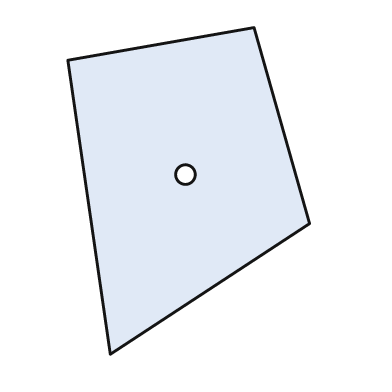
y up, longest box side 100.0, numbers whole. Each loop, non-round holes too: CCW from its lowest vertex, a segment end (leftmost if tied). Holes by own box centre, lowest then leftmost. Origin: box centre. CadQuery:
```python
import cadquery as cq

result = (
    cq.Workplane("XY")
    .moveTo(-24.0, -50.0)
    .lineTo(37.0, -10.0)
    .lineTo(20.0, 50.0)
    .lineTo(-37.0, 40.0)
    .close()
    .moveTo(-1.0, 5.0)
    .circle(3.0)
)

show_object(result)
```